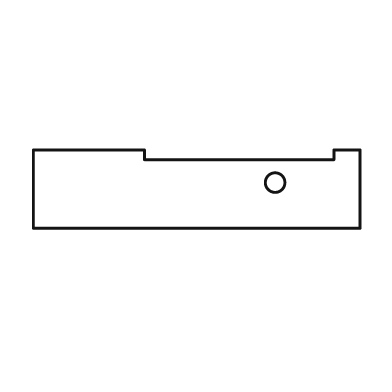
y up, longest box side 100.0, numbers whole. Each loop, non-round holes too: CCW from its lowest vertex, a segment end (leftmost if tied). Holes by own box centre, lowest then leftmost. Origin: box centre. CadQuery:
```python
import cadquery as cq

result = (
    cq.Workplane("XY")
    .moveTo(-50.0, -12.0)
    .lineTo(50.0, -12.0)
    .lineTo(50.0, 12.0)
    .lineTo(42.0, 12.0)
    .lineTo(42.0, 9.0)
    .lineTo(-16.0, 9.0)
    .lineTo(-16.0, 12.0)
    .lineTo(-50.0, 12.0)
    .close()
    .moveTo(24.0, 2.0)
    .circle(3.0)
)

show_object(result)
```